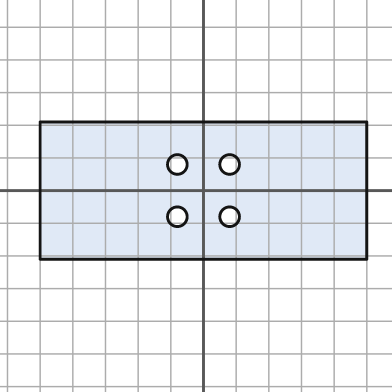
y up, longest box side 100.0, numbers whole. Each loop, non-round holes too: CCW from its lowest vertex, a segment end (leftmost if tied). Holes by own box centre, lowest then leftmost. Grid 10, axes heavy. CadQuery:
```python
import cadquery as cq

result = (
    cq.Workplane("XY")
    .moveTo(-50.0, -21.0)
    .lineTo(50.0, -21.0)
    .lineTo(50.0, 21.0)
    .lineTo(-50.0, 21.0)
    .close()
    .moveTo(-8.0, -8.0)
    .circle(3.0)
    .moveTo(8.0, -8.0)
    .circle(3.0)
    .moveTo(-8.0, 8.0)
    .circle(3.0)
    .moveTo(8.0, 8.0)
    .circle(3.0)
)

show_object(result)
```